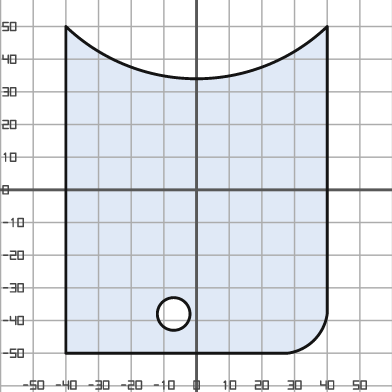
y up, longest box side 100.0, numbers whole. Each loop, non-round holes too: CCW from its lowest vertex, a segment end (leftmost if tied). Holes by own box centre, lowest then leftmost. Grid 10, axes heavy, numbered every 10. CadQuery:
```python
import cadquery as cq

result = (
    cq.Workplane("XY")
    .moveTo(-40.0, -50.0)
    .lineTo(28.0, -50.0)
    .threePointArc((36.0, -46.0), (40.0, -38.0))
    .lineTo(40.0, 50.0)
    .threePointArc((0.0, 34.0), (-40.0, 50.0))
    .close()
    .moveTo(-7.0, -38.0)
    .circle(5.0)
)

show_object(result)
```